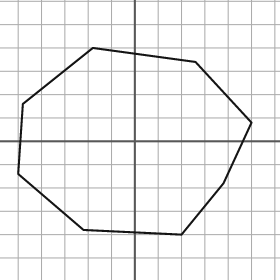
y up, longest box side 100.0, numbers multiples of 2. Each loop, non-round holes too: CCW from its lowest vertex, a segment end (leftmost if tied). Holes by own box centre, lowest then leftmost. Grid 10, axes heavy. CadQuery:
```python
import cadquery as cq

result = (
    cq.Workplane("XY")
    .moveTo(20.0, -40.0)
    .lineTo(38.0, -18.0)
    .lineTo(50.0, 8.0)
    .lineTo(26.0, 34.0)
    .lineTo(-18.0, 40.0)
    .lineTo(-48.0, 16.0)
    .lineTo(-50.0, -14.0)
    .lineTo(-22.0, -38.0)
    .close()
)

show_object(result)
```